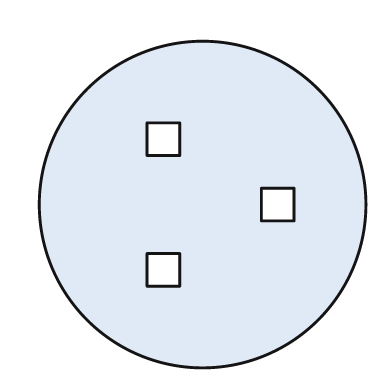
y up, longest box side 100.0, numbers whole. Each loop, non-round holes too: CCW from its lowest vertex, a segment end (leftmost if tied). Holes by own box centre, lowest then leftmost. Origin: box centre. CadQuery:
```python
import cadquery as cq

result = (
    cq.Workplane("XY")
    .moveTo(0.0, 0.0)
    .circle(50.0)
    .moveTo(-17.0, -25.0)
    .lineTo(-7.0, -25.0)
    .lineTo(-7.0, -15.0)
    .lineTo(-17.0, -15.0)
    .close()
    .moveTo(18.0, -5.0)
    .lineTo(28.0, -5.0)
    .lineTo(28.0, 5.0)
    .lineTo(18.0, 5.0)
    .close()
    .moveTo(-17.0, 15.0)
    .lineTo(-7.0, 15.0)
    .lineTo(-7.0, 25.0)
    .lineTo(-17.0, 25.0)
    .close()
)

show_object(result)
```